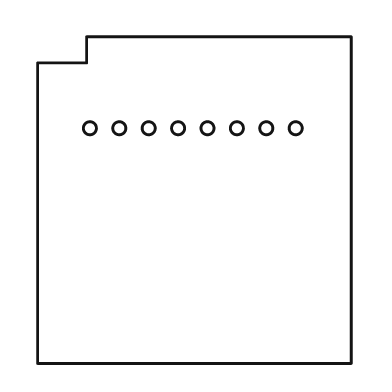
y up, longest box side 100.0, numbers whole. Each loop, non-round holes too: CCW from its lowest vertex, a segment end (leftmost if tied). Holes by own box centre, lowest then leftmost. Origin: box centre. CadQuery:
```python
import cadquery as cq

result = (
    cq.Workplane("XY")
    .moveTo(-48.0, -50.0)
    .lineTo(48.0, -50.0)
    .lineTo(48.0, 50.0)
    .lineTo(-33.0, 50.0)
    .lineTo(-33.0, 42.0)
    .lineTo(-48.0, 42.0)
    .close()
    .moveTo(-32.0, 22.0)
    .circle(2.0)
    .moveTo(-23.0, 22.0)
    .circle(2.0)
    .moveTo(-14.0, 22.0)
    .circle(2.0)
    .moveTo(-5.0, 22.0)
    .circle(2.0)
    .moveTo(4.0, 22.0)
    .circle(2.0)
    .moveTo(13.0, 22.0)
    .circle(2.0)
    .moveTo(22.0, 22.0)
    .circle(2.0)
    .moveTo(31.0, 22.0)
    .circle(2.0)
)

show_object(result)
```